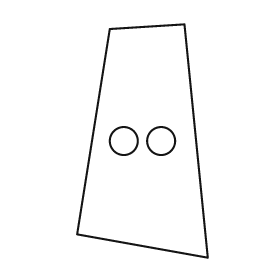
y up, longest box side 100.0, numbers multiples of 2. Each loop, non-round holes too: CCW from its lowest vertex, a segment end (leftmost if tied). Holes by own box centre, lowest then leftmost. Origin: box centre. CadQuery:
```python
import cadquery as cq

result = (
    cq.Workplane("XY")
    .moveTo(28.0, -50.0)
    .lineTo(18.0, 50.0)
    .lineTo(-14.0, 48.0)
    .lineTo(-28.0, -40.0)
    .close()
    .moveTo(-8.0, 0.0)
    .circle(6.0)
    .moveTo(8.0, 0.0)
    .circle(6.0)
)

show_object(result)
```